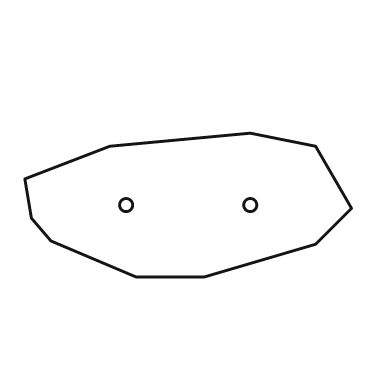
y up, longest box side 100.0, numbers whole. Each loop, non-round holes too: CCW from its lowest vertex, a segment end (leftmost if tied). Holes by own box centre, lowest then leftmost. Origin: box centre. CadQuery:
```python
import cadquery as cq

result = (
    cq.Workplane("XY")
    .moveTo(-16.0, -22.0)
    .lineTo(5.0, -22.0)
    .lineTo(39.0, -12.0)
    .lineTo(50.0, -1.0)
    .lineTo(39.0, 18.0)
    .lineTo(19.0, 22.0)
    .lineTo(-24.0, 18.0)
    .lineTo(-50.0, 8.0)
    .lineTo(-48.0, -4.0)
    .lineTo(-42.0, -11.0)
    .close()
    .moveTo(-19.0, 0.0)
    .circle(2.0)
    .moveTo(19.0, 0.0)
    .circle(2.0)
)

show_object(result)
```